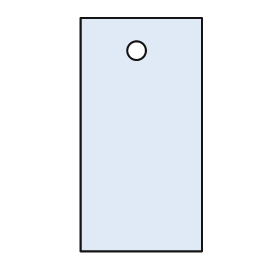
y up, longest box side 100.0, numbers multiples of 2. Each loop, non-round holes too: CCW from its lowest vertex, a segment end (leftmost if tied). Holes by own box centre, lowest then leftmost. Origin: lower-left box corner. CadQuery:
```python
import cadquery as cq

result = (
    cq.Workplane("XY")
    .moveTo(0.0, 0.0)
    .lineTo(52.0, 0.0)
    .lineTo(52.0, 100.0)
    .lineTo(0.0, 100.0)
    .close()
    .moveTo(24.0, 86.0)
    .circle(4.0)
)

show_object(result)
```